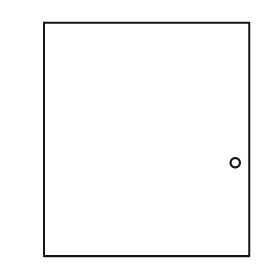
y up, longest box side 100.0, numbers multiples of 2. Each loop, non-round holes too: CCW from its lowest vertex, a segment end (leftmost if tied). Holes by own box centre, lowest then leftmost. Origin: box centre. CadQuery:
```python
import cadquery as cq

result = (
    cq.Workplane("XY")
    .moveTo(-44.0, -50.0)
    .lineTo(44.0, -50.0)
    .lineTo(44.0, 50.0)
    .lineTo(-44.0, 50.0)
    .close()
    .moveTo(38.0, -10.0)
    .circle(2.0)
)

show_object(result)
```